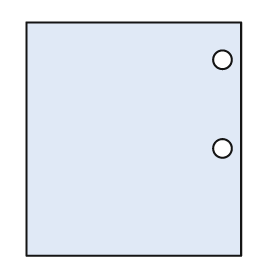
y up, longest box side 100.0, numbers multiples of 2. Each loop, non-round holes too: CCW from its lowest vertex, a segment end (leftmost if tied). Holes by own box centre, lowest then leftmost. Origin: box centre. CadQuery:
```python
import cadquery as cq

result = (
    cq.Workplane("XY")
    .moveTo(-46.0, -50.0)
    .lineTo(46.0, -50.0)
    .lineTo(46.0, 50.0)
    .lineTo(-46.0, 50.0)
    .close()
    .moveTo(38.0, -4.0)
    .circle(4.0)
    .moveTo(38.0, 34.0)
    .circle(4.0)
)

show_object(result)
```